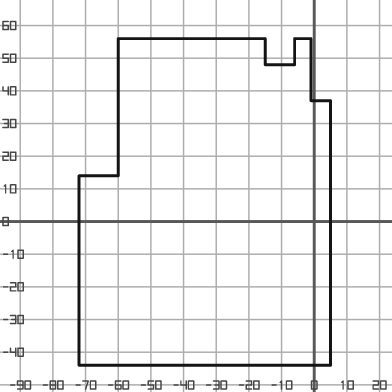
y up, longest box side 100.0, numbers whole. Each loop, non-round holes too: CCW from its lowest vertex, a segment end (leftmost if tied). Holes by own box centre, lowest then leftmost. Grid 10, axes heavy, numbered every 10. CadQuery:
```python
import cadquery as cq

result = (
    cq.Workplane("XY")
    .moveTo(-72.0, -44.0)
    .lineTo(5.0, -44.0)
    .lineTo(5.0, 37.0)
    .lineTo(-1.0, 37.0)
    .lineTo(-1.0, 56.0)
    .lineTo(-6.0, 56.0)
    .lineTo(-6.0, 48.0)
    .lineTo(-15.0, 48.0)
    .lineTo(-15.0, 56.0)
    .lineTo(-60.0, 56.0)
    .lineTo(-60.0, 14.0)
    .lineTo(-72.0, 14.0)
    .close()
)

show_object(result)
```